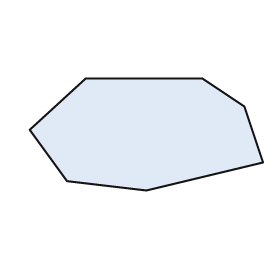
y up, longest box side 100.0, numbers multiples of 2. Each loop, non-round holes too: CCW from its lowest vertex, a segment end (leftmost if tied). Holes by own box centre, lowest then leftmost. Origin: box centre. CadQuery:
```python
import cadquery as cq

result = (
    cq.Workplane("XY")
    .moveTo(0.0, -24.0)
    .lineTo(50.0, -12.0)
    .lineTo(42.0, 12.0)
    .lineTo(24.0, 24.0)
    .lineTo(-26.0, 24.0)
    .lineTo(-50.0, 2.0)
    .lineTo(-34.0, -20.0)
    .close()
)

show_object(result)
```